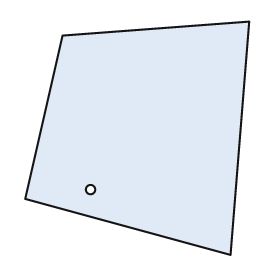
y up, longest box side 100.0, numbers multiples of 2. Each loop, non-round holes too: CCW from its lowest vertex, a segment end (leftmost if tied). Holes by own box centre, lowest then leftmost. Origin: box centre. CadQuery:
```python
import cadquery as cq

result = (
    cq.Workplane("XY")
    .moveTo(40.0, -50.0)
    .lineTo(48.0, 50.0)
    .lineTo(-32.0, 44.0)
    .lineTo(-48.0, -26.0)
    .close()
    .moveTo(-20.0, -22.0)
    .circle(2.0)
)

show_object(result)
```